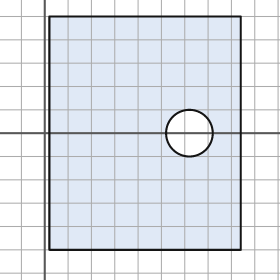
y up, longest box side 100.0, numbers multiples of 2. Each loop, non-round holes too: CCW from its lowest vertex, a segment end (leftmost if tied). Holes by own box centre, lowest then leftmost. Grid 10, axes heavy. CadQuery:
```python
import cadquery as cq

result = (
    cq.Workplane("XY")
    .moveTo(2.0, -50.0)
    .lineTo(84.0, -50.0)
    .lineTo(84.0, 50.0)
    .lineTo(2.0, 50.0)
    .close()
    .moveTo(62.0, 0.0)
    .circle(10.0)
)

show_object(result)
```